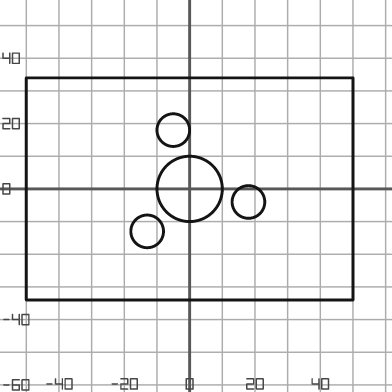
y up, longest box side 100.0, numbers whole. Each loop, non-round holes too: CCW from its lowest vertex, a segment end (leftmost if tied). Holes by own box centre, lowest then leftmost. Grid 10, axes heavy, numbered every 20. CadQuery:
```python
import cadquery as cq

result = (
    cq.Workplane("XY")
    .moveTo(-50.0, -34.0)
    .lineTo(50.0, -34.0)
    .lineTo(50.0, 34.0)
    .lineTo(-50.0, 34.0)
    .close()
    .moveTo(-13.0, -13.0)
    .circle(5.0)
    .moveTo(18.0, -4.0)
    .circle(5.0)
    .moveTo(0.0, 0.0)
    .circle(10.0)
    .moveTo(-5.0, 18.0)
    .circle(5.0)
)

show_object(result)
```